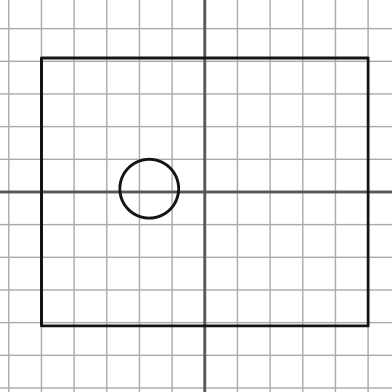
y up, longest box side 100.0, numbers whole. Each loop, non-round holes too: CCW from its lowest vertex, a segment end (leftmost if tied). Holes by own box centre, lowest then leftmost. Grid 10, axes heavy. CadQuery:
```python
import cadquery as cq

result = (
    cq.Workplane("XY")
    .moveTo(-50.0, -41.0)
    .lineTo(50.0, -41.0)
    .lineTo(50.0, 41.0)
    .lineTo(-50.0, 41.0)
    .close()
    .moveTo(-17.0, 1.0)
    .circle(9.0)
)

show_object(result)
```